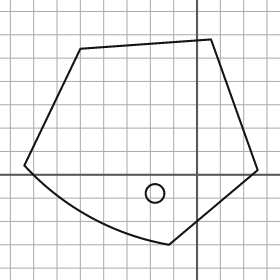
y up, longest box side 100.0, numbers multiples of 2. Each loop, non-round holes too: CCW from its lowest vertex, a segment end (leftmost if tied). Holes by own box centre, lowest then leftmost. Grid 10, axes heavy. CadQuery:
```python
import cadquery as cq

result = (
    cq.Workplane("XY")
    .moveTo(-12.0, -30.0)
    .lineTo(26.0, 2.0)
    .lineTo(6.0, 58.0)
    .lineTo(-50.0, 54.0)
    .lineTo(-74.0, 4.0)
    .threePointArc((-46.0, -18.0), (-12.0, -30.0))
    .close()
    .moveTo(-18.0, -8.0)
    .circle(4.0)
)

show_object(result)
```